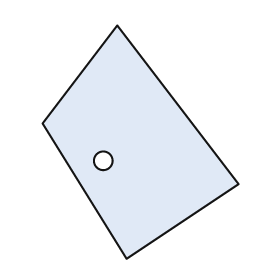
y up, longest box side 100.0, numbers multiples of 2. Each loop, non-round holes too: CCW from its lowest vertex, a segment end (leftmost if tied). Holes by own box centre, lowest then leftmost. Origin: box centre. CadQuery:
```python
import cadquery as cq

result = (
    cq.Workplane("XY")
    .moveTo(-6.0, -50.0)
    .lineTo(42.0, -18.0)
    .lineTo(-10.0, 50.0)
    .lineTo(-42.0, 8.0)
    .close()
    .moveTo(-16.0, -8.0)
    .circle(4.0)
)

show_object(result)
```